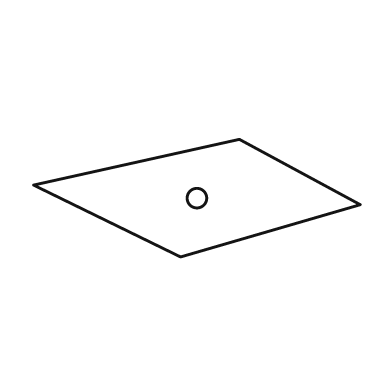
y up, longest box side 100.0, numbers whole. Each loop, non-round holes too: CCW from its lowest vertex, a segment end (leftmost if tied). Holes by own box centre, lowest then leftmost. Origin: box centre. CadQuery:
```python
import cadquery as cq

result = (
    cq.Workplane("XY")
    .moveTo(-5.0, -18.0)
    .lineTo(50.0, -2.0)
    .lineTo(13.0, 18.0)
    .lineTo(-50.0, 4.0)
    .close()
    .moveTo(0.0, 0.0)
    .circle(3.0)
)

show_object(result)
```